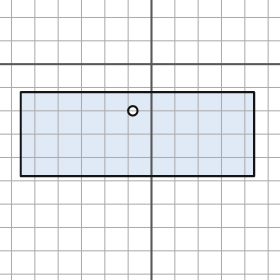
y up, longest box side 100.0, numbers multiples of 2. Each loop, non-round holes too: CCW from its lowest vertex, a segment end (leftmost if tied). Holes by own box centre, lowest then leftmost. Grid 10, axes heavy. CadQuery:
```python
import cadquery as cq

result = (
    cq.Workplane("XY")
    .moveTo(-56.0, -48.0)
    .lineTo(44.0, -48.0)
    .lineTo(44.0, -12.0)
    .lineTo(-56.0, -12.0)
    .close()
    .moveTo(-8.0, -20.0)
    .circle(2.0)
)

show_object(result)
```